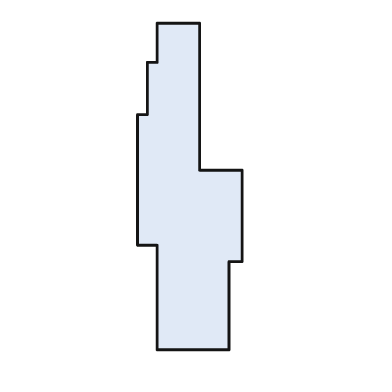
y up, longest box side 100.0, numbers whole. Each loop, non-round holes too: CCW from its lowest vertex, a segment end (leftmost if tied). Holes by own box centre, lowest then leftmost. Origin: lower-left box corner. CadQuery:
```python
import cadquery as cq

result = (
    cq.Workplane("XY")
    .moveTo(6.0, 0.0)
    .lineTo(28.0, 0.0)
    .lineTo(28.0, 27.0)
    .lineTo(32.0, 27.0)
    .lineTo(32.0, 55.0)
    .lineTo(19.0, 55.0)
    .lineTo(19.0, 100.0)
    .lineTo(6.0, 100.0)
    .lineTo(6.0, 88.0)
    .lineTo(3.0, 88.0)
    .lineTo(3.0, 72.0)
    .lineTo(0.0, 72.0)
    .lineTo(0.0, 32.0)
    .lineTo(6.0, 32.0)
    .close()
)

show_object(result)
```